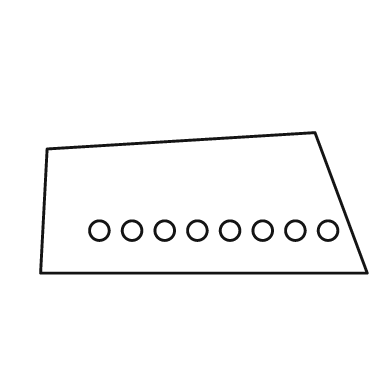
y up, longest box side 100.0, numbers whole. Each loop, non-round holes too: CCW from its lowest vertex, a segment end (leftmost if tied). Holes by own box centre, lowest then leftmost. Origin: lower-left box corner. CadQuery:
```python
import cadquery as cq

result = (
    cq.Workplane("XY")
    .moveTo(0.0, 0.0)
    .lineTo(100.0, 0.0)
    .lineTo(84.0, 43.0)
    .lineTo(2.0, 38.0)
    .close()
    .moveTo(18.0, 13.0)
    .circle(3.0)
    .moveTo(28.0, 13.0)
    .circle(3.0)
    .moveTo(38.0, 13.0)
    .circle(3.0)
    .moveTo(48.0, 13.0)
    .circle(3.0)
    .moveTo(58.0, 13.0)
    .circle(3.0)
    .moveTo(68.0, 13.0)
    .circle(3.0)
    .moveTo(78.0, 13.0)
    .circle(3.0)
    .moveTo(88.0, 13.0)
    .circle(3.0)
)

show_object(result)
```